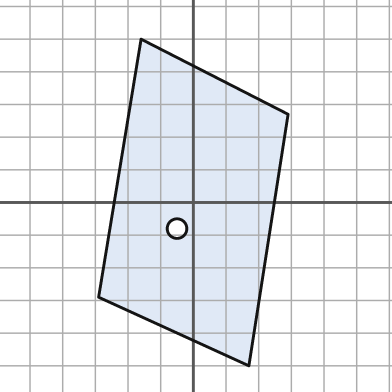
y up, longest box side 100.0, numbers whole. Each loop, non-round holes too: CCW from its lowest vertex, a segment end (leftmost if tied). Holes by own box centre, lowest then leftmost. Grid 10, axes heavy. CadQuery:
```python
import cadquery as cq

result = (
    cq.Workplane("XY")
    .moveTo(17.0, -50.0)
    .lineTo(29.0, 27.0)
    .lineTo(-16.0, 50.0)
    .lineTo(-29.0, -29.0)
    .close()
    .moveTo(-5.0, -8.0)
    .circle(3.0)
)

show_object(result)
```